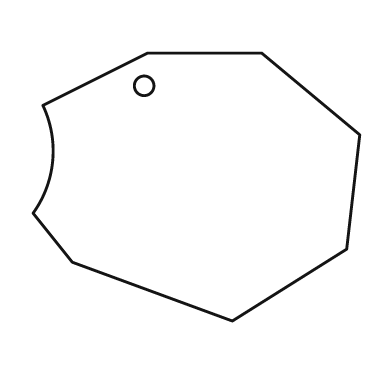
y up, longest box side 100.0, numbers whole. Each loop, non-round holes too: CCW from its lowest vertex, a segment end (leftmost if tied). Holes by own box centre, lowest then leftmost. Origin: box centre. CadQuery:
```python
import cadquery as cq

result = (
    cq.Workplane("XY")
    .moveTo(11.0, -41.0)
    .lineTo(46.0, -19.0)
    .lineTo(50.0, 16.0)
    .lineTo(20.0, 41.0)
    .lineTo(-15.0, 41.0)
    .lineTo(-47.0, 25.0)
    .threePointArc((-44.0, 8.0), (-50.0, -8.0))
    .lineTo(-38.0, -23.0)
    .close()
    .moveTo(-16.0, 31.0)
    .circle(3.0)
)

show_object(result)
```